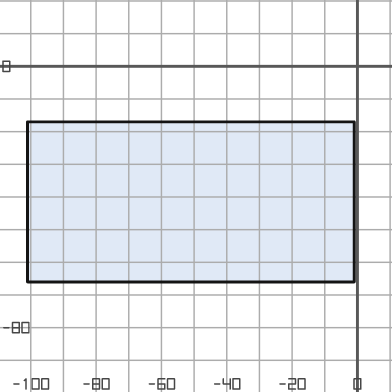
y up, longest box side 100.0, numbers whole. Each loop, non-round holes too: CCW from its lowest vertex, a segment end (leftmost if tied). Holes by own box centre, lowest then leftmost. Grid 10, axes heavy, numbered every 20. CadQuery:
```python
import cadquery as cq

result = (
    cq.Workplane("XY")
    .moveTo(-101.0, -66.0)
    .lineTo(-1.0, -66.0)
    .lineTo(-1.0, -17.0)
    .lineTo(-101.0, -17.0)
    .close()
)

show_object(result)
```